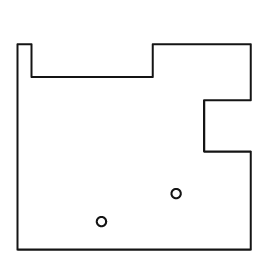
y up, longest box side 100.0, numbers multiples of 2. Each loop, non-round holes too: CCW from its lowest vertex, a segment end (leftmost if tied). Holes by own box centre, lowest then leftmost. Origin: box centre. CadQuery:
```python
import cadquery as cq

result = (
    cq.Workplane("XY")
    .moveTo(-50.0, -44.0)
    .lineTo(50.0, -44.0)
    .lineTo(50.0, -2.0)
    .lineTo(30.0, -2.0)
    .lineTo(30.0, 20.0)
    .lineTo(50.0, 20.0)
    .lineTo(50.0, 44.0)
    .lineTo(8.0, 44.0)
    .lineTo(8.0, 30.0)
    .lineTo(-44.0, 30.0)
    .lineTo(-44.0, 44.0)
    .lineTo(-50.0, 44.0)
    .close()
    .moveTo(-14.0, -32.0)
    .circle(2.0)
    .moveTo(18.0, -20.0)
    .circle(2.0)
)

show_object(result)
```